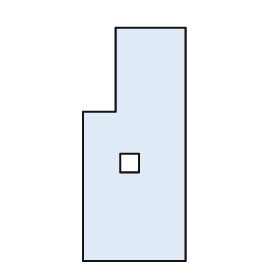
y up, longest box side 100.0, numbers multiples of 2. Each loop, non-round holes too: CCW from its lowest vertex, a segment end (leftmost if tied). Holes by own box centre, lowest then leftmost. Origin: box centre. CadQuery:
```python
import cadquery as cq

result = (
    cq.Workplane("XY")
    .moveTo(-22.0, -50.0)
    .lineTo(22.0, -50.0)
    .lineTo(22.0, 50.0)
    .lineTo(-8.0, 50.0)
    .lineTo(-8.0, 14.0)
    .lineTo(-22.0, 14.0)
    .close()
    .moveTo(-6.0, -12.0)
    .lineTo(2.0, -12.0)
    .lineTo(2.0, -4.0)
    .lineTo(-6.0, -4.0)
    .close()
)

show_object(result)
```